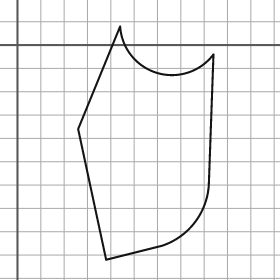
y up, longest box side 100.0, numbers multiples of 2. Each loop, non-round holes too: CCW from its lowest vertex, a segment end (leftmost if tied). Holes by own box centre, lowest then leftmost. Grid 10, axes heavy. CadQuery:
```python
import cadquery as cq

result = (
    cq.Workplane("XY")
    .moveTo(38.0, -92.0)
    .lineTo(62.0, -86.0)
    .threePointArc((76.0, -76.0), (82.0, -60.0))
    .lineTo(84.0, -4.0)
    .threePointArc((60.0, -12.0), (44.0, 8.0))
    .lineTo(26.0, -36.0)
    .close()
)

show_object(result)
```